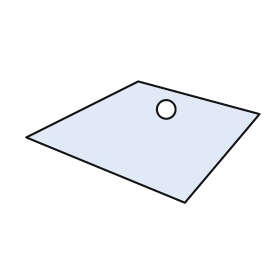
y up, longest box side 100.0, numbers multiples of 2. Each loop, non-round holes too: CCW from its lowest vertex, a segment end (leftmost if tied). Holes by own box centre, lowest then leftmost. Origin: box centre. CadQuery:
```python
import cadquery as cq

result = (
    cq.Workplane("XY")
    .moveTo(18.0, -26.0)
    .lineTo(50.0, 12.0)
    .lineTo(-2.0, 26.0)
    .lineTo(-50.0, 2.0)
    .close()
    .moveTo(10.0, 14.0)
    .circle(4.0)
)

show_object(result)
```